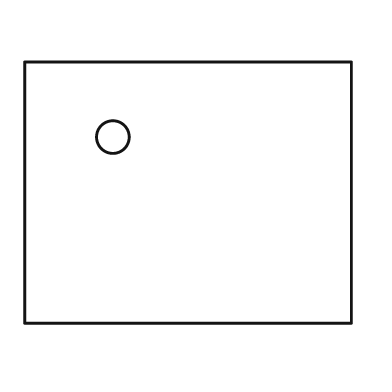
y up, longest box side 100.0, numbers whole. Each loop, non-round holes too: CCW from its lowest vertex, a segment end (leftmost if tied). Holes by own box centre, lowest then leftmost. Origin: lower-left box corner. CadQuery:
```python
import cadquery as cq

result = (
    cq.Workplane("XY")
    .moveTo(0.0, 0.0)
    .lineTo(100.0, 0.0)
    .lineTo(100.0, 80.0)
    .lineTo(0.0, 80.0)
    .close()
    .moveTo(27.0, 57.0)
    .circle(5.0)
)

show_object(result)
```